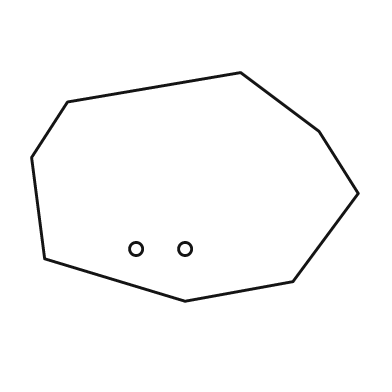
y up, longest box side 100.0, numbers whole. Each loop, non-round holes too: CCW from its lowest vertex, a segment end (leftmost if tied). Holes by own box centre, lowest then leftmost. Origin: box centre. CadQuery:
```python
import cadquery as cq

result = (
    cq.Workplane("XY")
    .moveTo(-3.0, -35.0)
    .lineTo(30.0, -29.0)
    .lineTo(50.0, -2.0)
    .lineTo(38.0, 17.0)
    .lineTo(14.0, 35.0)
    .lineTo(-39.0, 26.0)
    .lineTo(-50.0, 9.0)
    .lineTo(-46.0, -22.0)
    .close()
    .moveTo(-18.0, -19.0)
    .circle(2.0)
    .moveTo(-3.0, -19.0)
    .circle(2.0)
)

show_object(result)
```